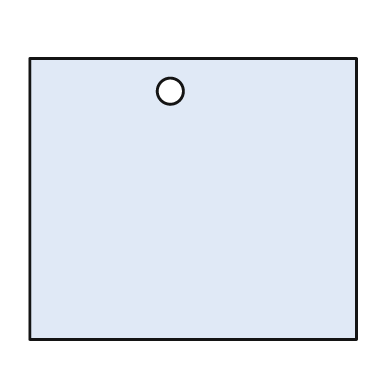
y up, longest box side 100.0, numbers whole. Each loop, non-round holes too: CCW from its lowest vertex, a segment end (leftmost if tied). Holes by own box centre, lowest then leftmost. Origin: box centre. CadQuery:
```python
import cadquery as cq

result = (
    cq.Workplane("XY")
    .moveTo(-50.0, -43.0)
    .lineTo(50.0, -43.0)
    .lineTo(50.0, 43.0)
    .lineTo(-50.0, 43.0)
    .close()
    .moveTo(-7.0, 33.0)
    .circle(4.0)
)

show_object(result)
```